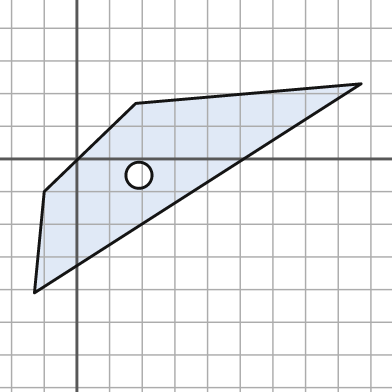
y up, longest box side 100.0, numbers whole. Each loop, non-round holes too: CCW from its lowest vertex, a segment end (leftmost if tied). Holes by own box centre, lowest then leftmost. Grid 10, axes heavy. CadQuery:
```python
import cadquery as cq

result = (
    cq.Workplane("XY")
    .moveTo(-13.0, -41.0)
    .lineTo(87.0, 23.0)
    .lineTo(18.0, 17.0)
    .lineTo(-10.0, -10.0)
    .close()
    .moveTo(19.0, -5.0)
    .circle(4.0)
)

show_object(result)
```